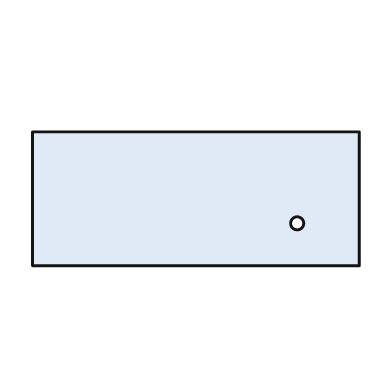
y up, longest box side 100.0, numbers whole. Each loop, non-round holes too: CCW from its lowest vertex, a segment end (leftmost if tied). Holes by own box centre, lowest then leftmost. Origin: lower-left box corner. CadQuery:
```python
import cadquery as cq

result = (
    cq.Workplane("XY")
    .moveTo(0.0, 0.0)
    .lineTo(100.0, 0.0)
    .lineTo(100.0, 41.0)
    .lineTo(0.0, 41.0)
    .close()
    .moveTo(81.0, 13.0)
    .circle(2.0)
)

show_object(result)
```